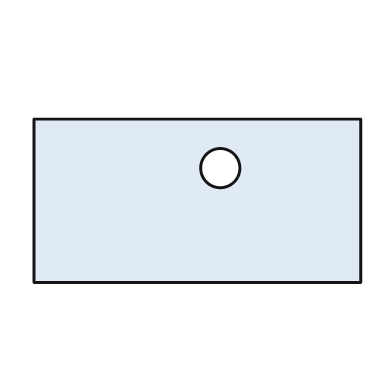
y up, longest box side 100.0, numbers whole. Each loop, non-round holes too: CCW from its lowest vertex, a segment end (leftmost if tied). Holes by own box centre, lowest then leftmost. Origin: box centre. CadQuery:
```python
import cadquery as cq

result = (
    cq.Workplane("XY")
    .moveTo(-50.0, -25.0)
    .lineTo(50.0, -25.0)
    .lineTo(50.0, 25.0)
    .lineTo(-50.0, 25.0)
    .close()
    .moveTo(7.0, 10.0)
    .circle(6.0)
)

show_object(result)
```